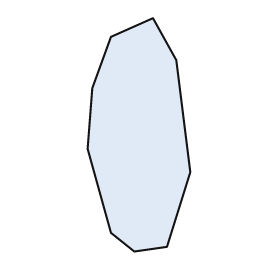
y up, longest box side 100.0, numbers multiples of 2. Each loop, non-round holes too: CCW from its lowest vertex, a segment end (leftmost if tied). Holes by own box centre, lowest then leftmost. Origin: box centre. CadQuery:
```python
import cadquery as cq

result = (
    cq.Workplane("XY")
    .moveTo(-2.0, -50.0)
    .lineTo(12.0, -48.0)
    .lineTo(22.0, -16.0)
    .lineTo(16.0, 32.0)
    .lineTo(6.0, 50.0)
    .lineTo(-12.0, 42.0)
    .lineTo(-20.0, 20.0)
    .lineTo(-22.0, -6.0)
    .lineTo(-12.0, -42.0)
    .close()
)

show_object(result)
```